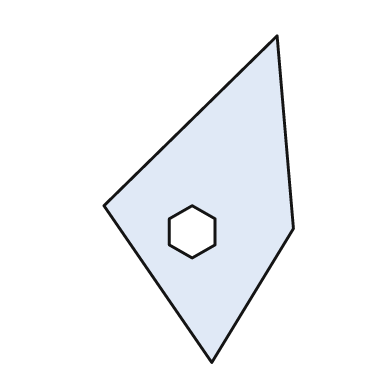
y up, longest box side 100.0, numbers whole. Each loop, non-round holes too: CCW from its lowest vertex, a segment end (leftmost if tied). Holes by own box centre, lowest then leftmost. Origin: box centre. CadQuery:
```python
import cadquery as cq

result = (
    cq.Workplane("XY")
    .moveTo(4.0, -50.0)
    .lineTo(29.0, -9.0)
    .lineTo(24.0, 50.0)
    .lineTo(-29.0, -2.0)
    .close()
    .moveTo(-2.0, -18.0)
    .lineTo(5.0, -14.0)
    .lineTo(5.0, -6.0)
    .lineTo(-2.0, -2.0)
    .lineTo(-9.0, -6.0)
    .lineTo(-9.0, -14.0)
    .close()
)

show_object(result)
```